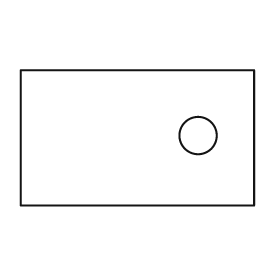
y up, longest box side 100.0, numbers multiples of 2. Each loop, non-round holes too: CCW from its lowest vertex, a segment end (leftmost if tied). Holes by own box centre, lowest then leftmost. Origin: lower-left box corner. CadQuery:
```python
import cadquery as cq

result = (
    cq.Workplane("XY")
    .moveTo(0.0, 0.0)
    .lineTo(100.0, 0.0)
    .lineTo(100.0, 58.0)
    .lineTo(0.0, 58.0)
    .close()
    .moveTo(76.0, 30.0)
    .circle(8.0)
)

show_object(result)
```